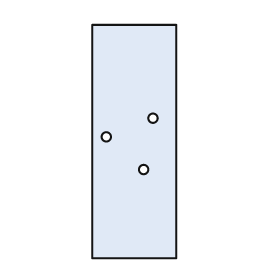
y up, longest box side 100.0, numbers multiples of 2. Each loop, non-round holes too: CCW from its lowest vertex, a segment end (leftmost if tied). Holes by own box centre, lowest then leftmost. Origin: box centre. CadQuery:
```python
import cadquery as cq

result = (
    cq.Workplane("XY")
    .moveTo(-18.0, -50.0)
    .lineTo(18.0, -50.0)
    .lineTo(18.0, 50.0)
    .lineTo(-18.0, 50.0)
    .close()
    .moveTo(4.0, -12.0)
    .circle(2.0)
    .moveTo(-12.0, 2.0)
    .circle(2.0)
    .moveTo(8.0, 10.0)
    .circle(2.0)
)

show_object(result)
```